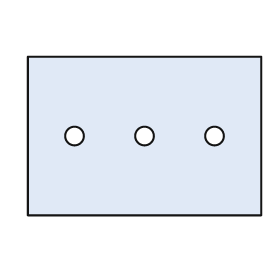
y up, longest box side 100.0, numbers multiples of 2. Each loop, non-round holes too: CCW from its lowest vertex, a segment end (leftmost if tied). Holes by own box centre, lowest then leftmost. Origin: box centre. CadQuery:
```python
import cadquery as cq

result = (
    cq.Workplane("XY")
    .moveTo(-50.0, -34.0)
    .lineTo(50.0, -34.0)
    .lineTo(50.0, 34.0)
    .lineTo(-50.0, 34.0)
    .close()
    .moveTo(-30.0, 0.0)
    .circle(4.0)
    .moveTo(0.0, 0.0)
    .circle(4.0)
    .moveTo(30.0, 0.0)
    .circle(4.0)
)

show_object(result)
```